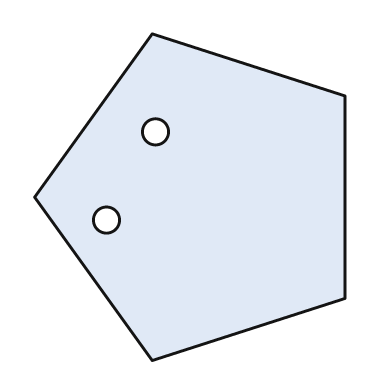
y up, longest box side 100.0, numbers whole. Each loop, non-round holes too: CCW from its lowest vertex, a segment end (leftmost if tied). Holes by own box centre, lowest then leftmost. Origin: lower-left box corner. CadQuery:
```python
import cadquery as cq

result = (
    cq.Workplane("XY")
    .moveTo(36.0, 0.0)
    .lineTo(95.0, 19.0)
    .lineTo(95.0, 81.0)
    .lineTo(36.0, 100.0)
    .lineTo(0.0, 50.0)
    .close()
    .moveTo(22.0, 43.0)
    .circle(4.0)
    .moveTo(37.0, 70.0)
    .circle(4.0)
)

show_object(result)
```